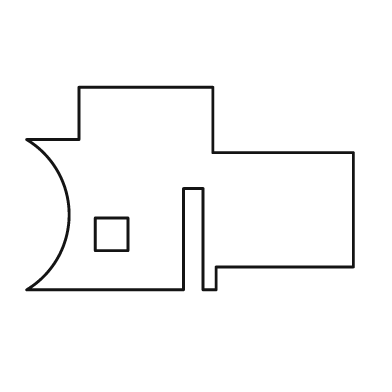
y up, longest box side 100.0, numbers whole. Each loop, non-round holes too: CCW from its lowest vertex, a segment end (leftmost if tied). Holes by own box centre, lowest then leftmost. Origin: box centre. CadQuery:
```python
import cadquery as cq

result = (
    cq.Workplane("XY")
    .moveTo(-50.0, -31.0)
    .lineTo(-2.0, -31.0)
    .lineTo(-2.0, 0.0)
    .lineTo(4.0, 0.0)
    .lineTo(4.0, -31.0)
    .lineTo(8.0, -31.0)
    .lineTo(8.0, -24.0)
    .lineTo(50.0, -24.0)
    .lineTo(50.0, 11.0)
    .lineTo(7.0, 11.0)
    .lineTo(7.0, 31.0)
    .lineTo(-34.0, 31.0)
    .lineTo(-34.0, 15.0)
    .lineTo(-50.0, 15.0)
    .threePointArc((-37.0, -8.0), (-50.0, -31.0))
    .close()
    .moveTo(-29.0, -19.0)
    .lineTo(-19.0, -19.0)
    .lineTo(-19.0, -9.0)
    .lineTo(-29.0, -9.0)
    .close()
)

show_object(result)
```